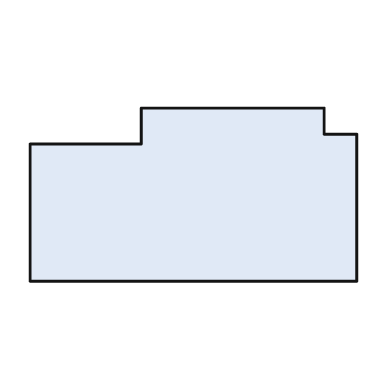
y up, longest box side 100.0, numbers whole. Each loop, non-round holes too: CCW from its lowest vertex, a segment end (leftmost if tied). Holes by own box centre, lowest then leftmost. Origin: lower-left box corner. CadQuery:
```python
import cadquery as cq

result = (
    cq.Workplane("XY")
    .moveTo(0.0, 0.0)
    .lineTo(100.0, 0.0)
    .lineTo(100.0, 45.0)
    .lineTo(90.0, 45.0)
    .lineTo(90.0, 53.0)
    .lineTo(34.0, 53.0)
    .lineTo(34.0, 42.0)
    .lineTo(0.0, 42.0)
    .close()
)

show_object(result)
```